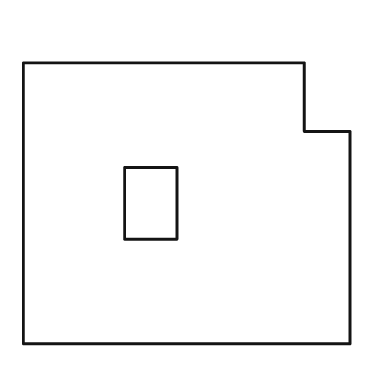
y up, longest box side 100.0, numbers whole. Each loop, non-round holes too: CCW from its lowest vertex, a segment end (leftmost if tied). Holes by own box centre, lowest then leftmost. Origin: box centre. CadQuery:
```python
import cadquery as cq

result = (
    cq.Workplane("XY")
    .moveTo(-50.0, -43.0)
    .lineTo(50.0, -43.0)
    .lineTo(50.0, 22.0)
    .lineTo(36.0, 22.0)
    .lineTo(36.0, 43.0)
    .lineTo(-50.0, 43.0)
    .close()
    .moveTo(-19.0, -11.0)
    .lineTo(-3.0, -11.0)
    .lineTo(-3.0, 11.0)
    .lineTo(-19.0, 11.0)
    .close()
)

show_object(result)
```